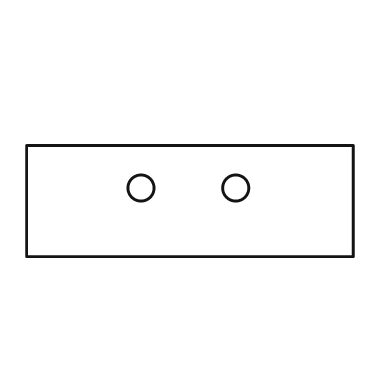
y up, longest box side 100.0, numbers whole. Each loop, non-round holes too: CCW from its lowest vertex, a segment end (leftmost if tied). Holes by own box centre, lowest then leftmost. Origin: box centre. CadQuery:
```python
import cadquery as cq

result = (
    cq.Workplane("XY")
    .moveTo(-50.0, -17.0)
    .lineTo(50.0, -17.0)
    .lineTo(50.0, 17.0)
    .lineTo(-50.0, 17.0)
    .close()
    .moveTo(-15.0, 4.0)
    .circle(4.0)
    .moveTo(14.0, 4.0)
    .circle(4.0)
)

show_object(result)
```